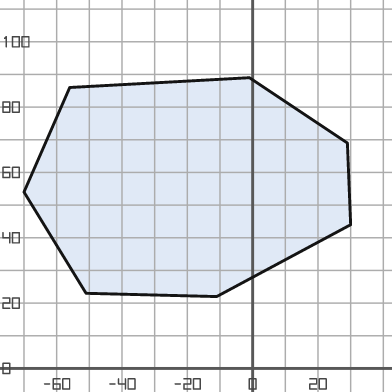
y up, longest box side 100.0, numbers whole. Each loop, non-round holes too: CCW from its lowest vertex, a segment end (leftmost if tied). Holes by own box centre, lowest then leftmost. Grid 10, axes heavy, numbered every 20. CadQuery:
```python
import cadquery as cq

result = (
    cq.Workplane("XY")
    .moveTo(-11.0, 22.0)
    .lineTo(30.0, 44.0)
    .lineTo(29.0, 69.0)
    .lineTo(-1.0, 89.0)
    .lineTo(-56.0, 86.0)
    .lineTo(-70.0, 54.0)
    .lineTo(-51.0, 23.0)
    .close()
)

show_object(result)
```